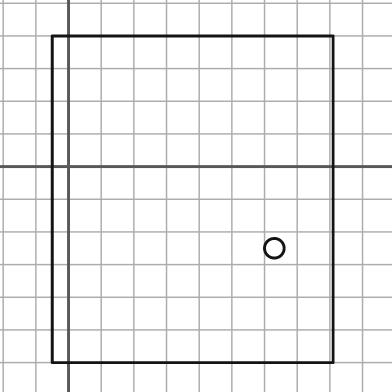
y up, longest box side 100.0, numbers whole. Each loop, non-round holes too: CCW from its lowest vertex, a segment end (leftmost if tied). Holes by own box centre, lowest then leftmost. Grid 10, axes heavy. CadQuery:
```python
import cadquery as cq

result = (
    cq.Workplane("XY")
    .moveTo(-5.0, -60.0)
    .lineTo(81.0, -60.0)
    .lineTo(81.0, 40.0)
    .lineTo(-5.0, 40.0)
    .close()
    .moveTo(63.0, -25.0)
    .circle(3.0)
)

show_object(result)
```